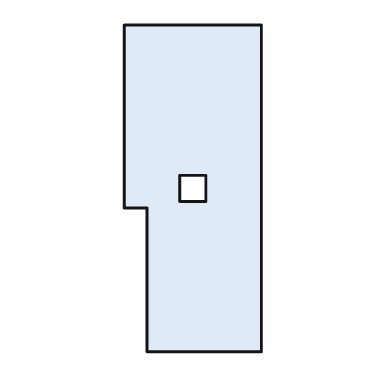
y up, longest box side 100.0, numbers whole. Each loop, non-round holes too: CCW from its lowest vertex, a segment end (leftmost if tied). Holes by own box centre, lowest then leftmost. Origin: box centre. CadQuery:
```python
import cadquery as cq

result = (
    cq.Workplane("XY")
    .moveTo(-14.0, -50.0)
    .lineTo(21.0, -50.0)
    .lineTo(21.0, 50.0)
    .lineTo(-21.0, 50.0)
    .lineTo(-21.0, -6.0)
    .lineTo(-14.0, -6.0)
    .close()
    .moveTo(-4.0, -4.0)
    .lineTo(4.0, -4.0)
    .lineTo(4.0, 4.0)
    .lineTo(-4.0, 4.0)
    .close()
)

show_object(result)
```